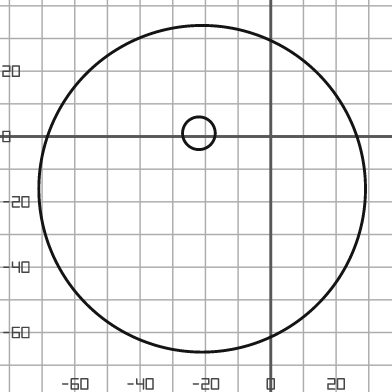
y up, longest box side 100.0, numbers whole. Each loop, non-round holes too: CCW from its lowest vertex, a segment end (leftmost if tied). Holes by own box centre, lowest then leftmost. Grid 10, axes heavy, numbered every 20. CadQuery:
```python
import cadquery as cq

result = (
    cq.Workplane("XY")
    .moveTo(-21.0, -16.0)
    .circle(50.0)
    .moveTo(-22.0, 1.0)
    .circle(5.0)
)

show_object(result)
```